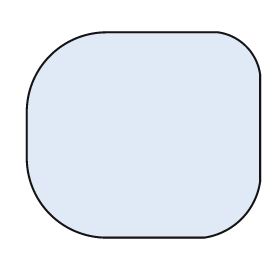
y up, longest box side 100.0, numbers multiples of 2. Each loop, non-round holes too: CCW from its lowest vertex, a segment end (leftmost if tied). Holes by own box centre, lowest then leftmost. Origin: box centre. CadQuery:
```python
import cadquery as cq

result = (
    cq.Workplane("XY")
    .moveTo(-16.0, -44.0)
    .lineTo(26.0, -44.0)
    .threePointArc((42.0, -36.0), (50.0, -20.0))
    .lineTo(50.0, 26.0)
    .threePointArc((44.0, 38.0), (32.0, 44.0))
    .lineTo(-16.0, 44.0)
    .threePointArc((-40.0, 34.0), (-50.0, 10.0))
    .lineTo(-50.0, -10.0)
    .threePointArc((-40.0, -34.0), (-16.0, -44.0))
    .close()
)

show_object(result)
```